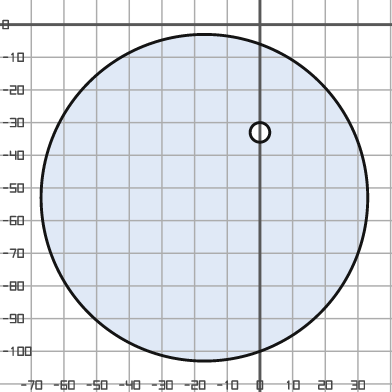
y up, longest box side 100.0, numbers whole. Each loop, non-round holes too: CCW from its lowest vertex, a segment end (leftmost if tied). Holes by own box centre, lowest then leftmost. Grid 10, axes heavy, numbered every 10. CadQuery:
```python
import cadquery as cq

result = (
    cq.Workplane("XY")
    .moveTo(-17.0, -53.0)
    .circle(50.0)
    .moveTo(0.0, -33.0)
    .circle(3.0)
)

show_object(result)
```